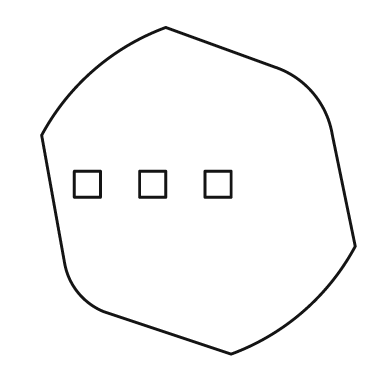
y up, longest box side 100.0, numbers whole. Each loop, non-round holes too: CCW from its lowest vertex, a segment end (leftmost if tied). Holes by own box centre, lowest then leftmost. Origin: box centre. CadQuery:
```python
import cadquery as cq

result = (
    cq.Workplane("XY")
    .moveTo(10.0, -50.0)
    .threePointArc((32.0, -37.0), (48.0, -17.0))
    .lineTo(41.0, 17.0)
    .threePointArc((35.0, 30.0), (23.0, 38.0))
    .lineTo(-10.0, 50.0)
    .threePointArc((-32.0, 37.0), (-48.0, 17.0))
    .lineTo(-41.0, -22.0)
    .threePointArc((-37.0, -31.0), (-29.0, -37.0))
    .close()
    .moveTo(-38.0, -2.0)
    .lineTo(-30.0, -2.0)
    .lineTo(-30.0, 6.0)
    .lineTo(-38.0, 6.0)
    .close()
    .moveTo(-18.0, -2.0)
    .lineTo(-10.0, -2.0)
    .lineTo(-10.0, 6.0)
    .lineTo(-18.0, 6.0)
    .close()
    .moveTo(2.0, -2.0)
    .lineTo(10.0, -2.0)
    .lineTo(10.0, 6.0)
    .lineTo(2.0, 6.0)
    .close()
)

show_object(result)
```